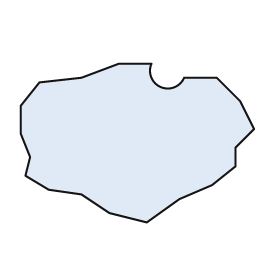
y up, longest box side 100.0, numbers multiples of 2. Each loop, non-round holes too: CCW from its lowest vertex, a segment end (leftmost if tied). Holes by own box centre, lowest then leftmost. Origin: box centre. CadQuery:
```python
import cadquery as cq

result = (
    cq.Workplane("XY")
    .moveTo(4.0, -34.0)
    .lineTo(18.0, -24.0)
    .lineTo(32.0, -18.0)
    .lineTo(42.0, -10.0)
    .lineTo(42.0, -2.0)
    .lineTo(50.0, 6.0)
    .lineTo(44.0, 18.0)
    .lineTo(34.0, 28.0)
    .lineTo(20.0, 28.0)
    .threePointArc((10.0, 24.0), (6.0, 34.0))
    .lineTo(-8.0, 34.0)
    .lineTo(-24.0, 28.0)
    .lineTo(-42.0, 26.0)
    .lineTo(-50.0, 16.0)
    .lineTo(-50.0, 4.0)
    .lineTo(-46.0, -6.0)
    .lineTo(-48.0, -14.0)
    .lineTo(-38.0, -20.0)
    .lineTo(-24.0, -22.0)
    .lineTo(-12.0, -30.0)
    .close()
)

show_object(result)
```